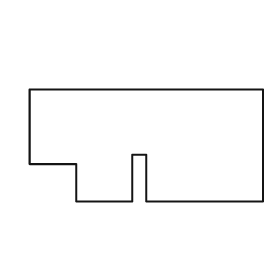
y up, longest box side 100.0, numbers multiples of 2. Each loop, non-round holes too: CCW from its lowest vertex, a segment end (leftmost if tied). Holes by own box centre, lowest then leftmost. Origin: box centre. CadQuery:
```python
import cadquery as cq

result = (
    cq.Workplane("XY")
    .moveTo(-30.0, -24.0)
    .lineTo(-6.0, -24.0)
    .lineTo(-6.0, -4.0)
    .lineTo(0.0, -4.0)
    .lineTo(0.0, -24.0)
    .lineTo(50.0, -24.0)
    .lineTo(50.0, 24.0)
    .lineTo(-50.0, 24.0)
    .lineTo(-50.0, -8.0)
    .lineTo(-30.0, -8.0)
    .close()
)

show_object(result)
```